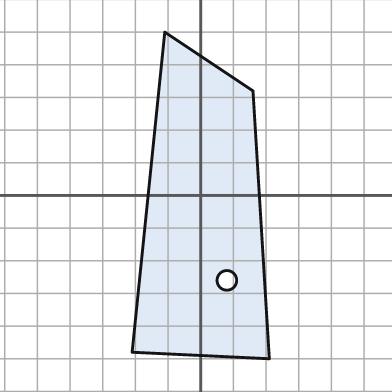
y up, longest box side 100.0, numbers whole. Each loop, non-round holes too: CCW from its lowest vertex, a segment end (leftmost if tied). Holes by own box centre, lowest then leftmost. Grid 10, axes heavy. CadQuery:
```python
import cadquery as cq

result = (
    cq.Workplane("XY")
    .moveTo(21.0, -50.0)
    .lineTo(16.0, 32.0)
    .lineTo(-11.0, 50.0)
    .lineTo(-21.0, -48.0)
    .close()
    .moveTo(8.0, -26.0)
    .circle(3.0)
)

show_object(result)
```